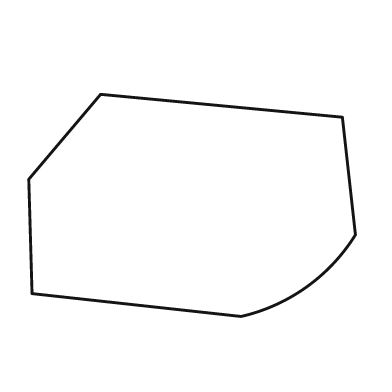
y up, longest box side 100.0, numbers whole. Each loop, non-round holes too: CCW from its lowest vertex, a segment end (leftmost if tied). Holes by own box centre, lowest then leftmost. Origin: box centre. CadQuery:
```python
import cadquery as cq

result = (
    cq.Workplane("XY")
    .moveTo(15.0, -34.0)
    .threePointArc((35.0, -25.0), (50.0, -9.0))
    .lineTo(46.0, 27.0)
    .lineTo(-28.0, 34.0)
    .lineTo(-50.0, 8.0)
    .lineTo(-49.0, -27.0)
    .close()
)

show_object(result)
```